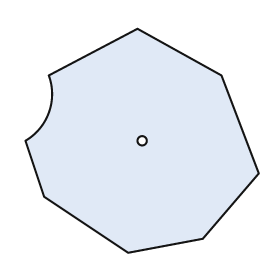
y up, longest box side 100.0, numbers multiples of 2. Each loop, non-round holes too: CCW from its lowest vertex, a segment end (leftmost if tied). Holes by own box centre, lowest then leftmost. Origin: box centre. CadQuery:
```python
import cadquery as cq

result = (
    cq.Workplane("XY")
    .moveTo(-6.0, -48.0)
    .lineTo(26.0, -42.0)
    .lineTo(50.0, -14.0)
    .lineTo(34.0, 28.0)
    .lineTo(-2.0, 48.0)
    .lineTo(-40.0, 28.0)
    .threePointArc((-40.0, 12.0), (-50.0, 0.0))
    .lineTo(-42.0, -24.0)
    .close()
    .moveTo(0.0, 0.0)
    .circle(2.0)
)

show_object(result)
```